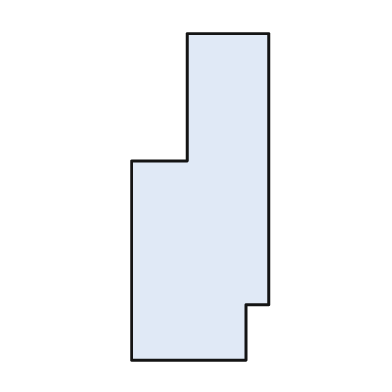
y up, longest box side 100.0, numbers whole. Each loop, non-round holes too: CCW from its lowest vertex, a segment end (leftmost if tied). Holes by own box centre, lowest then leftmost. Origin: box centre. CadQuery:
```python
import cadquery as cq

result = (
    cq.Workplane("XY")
    .moveTo(-21.0, -50.0)
    .lineTo(14.0, -50.0)
    .lineTo(14.0, -33.0)
    .lineTo(21.0, -33.0)
    .lineTo(21.0, 50.0)
    .lineTo(-4.0, 50.0)
    .lineTo(-4.0, 11.0)
    .lineTo(-21.0, 11.0)
    .close()
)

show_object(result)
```